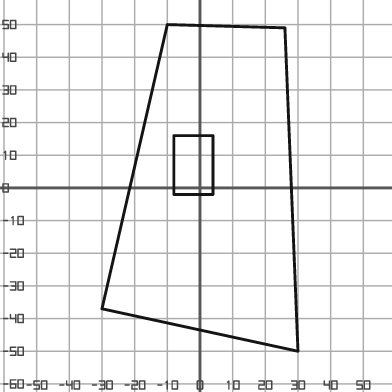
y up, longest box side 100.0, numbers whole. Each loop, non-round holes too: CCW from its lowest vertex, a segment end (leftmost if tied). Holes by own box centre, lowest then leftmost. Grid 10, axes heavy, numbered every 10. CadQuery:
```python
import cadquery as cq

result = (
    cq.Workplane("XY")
    .moveTo(30.0, -50.0)
    .lineTo(26.0, 49.0)
    .lineTo(-10.0, 50.0)
    .lineTo(-30.0, -37.0)
    .close()
    .moveTo(-8.0, -2.0)
    .lineTo(4.0, -2.0)
    .lineTo(4.0, 16.0)
    .lineTo(-8.0, 16.0)
    .close()
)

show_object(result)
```